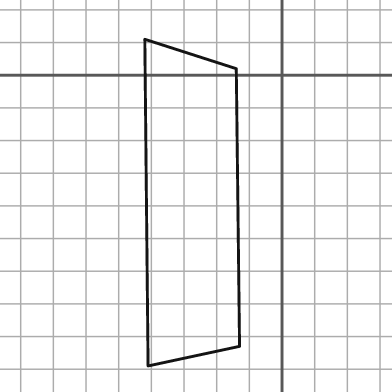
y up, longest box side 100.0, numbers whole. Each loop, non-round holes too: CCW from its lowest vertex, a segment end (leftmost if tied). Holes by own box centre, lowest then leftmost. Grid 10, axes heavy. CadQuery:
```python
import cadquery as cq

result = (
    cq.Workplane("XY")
    .moveTo(-41.0, -89.0)
    .lineTo(-13.0, -83.0)
    .lineTo(-14.0, 2.0)
    .lineTo(-42.0, 11.0)
    .close()
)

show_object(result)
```